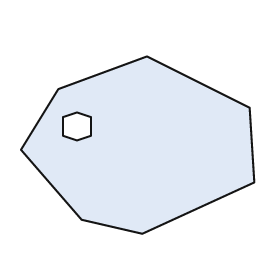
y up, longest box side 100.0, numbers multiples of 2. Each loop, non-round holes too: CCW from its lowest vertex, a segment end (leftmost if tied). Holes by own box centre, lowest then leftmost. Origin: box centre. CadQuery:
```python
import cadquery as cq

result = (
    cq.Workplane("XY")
    .moveTo(2.0, -38.0)
    .lineTo(50.0, -16.0)
    .lineTo(48.0, 16.0)
    .lineTo(4.0, 38.0)
    .lineTo(-34.0, 24.0)
    .lineTo(-50.0, -2.0)
    .lineTo(-24.0, -32.0)
    .close()
    .moveTo(-26.0, 2.0)
    .lineTo(-20.0, 4.0)
    .lineTo(-20.0, 12.0)
    .lineTo(-26.0, 14.0)
    .lineTo(-32.0, 12.0)
    .lineTo(-32.0, 4.0)
    .close()
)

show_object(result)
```